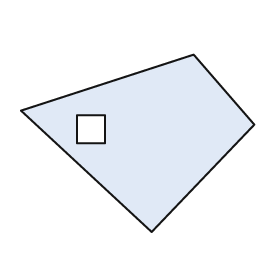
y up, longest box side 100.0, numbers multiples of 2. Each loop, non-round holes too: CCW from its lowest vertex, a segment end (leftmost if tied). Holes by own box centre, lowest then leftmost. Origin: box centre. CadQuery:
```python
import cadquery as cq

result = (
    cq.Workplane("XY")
    .moveTo(6.0, -38.0)
    .lineTo(50.0, 8.0)
    .lineTo(24.0, 38.0)
    .lineTo(-50.0, 14.0)
    .close()
    .moveTo(-26.0, 0.0)
    .lineTo(-14.0, 0.0)
    .lineTo(-14.0, 12.0)
    .lineTo(-26.0, 12.0)
    .close()
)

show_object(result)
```